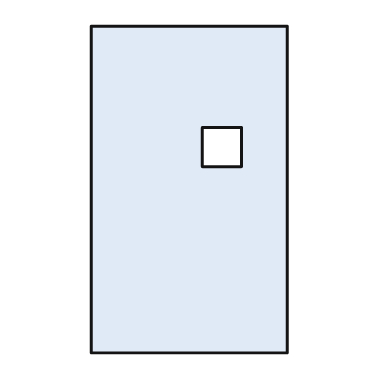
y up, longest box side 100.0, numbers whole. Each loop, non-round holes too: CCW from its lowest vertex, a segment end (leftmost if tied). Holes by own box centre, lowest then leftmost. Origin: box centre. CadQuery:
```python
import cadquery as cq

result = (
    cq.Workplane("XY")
    .moveTo(-30.0, -50.0)
    .lineTo(30.0, -50.0)
    .lineTo(30.0, 50.0)
    .lineTo(-30.0, 50.0)
    .close()
    .moveTo(4.0, 7.0)
    .lineTo(16.0, 7.0)
    .lineTo(16.0, 19.0)
    .lineTo(4.0, 19.0)
    .close()
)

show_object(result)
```